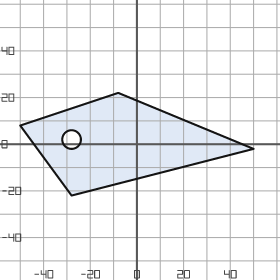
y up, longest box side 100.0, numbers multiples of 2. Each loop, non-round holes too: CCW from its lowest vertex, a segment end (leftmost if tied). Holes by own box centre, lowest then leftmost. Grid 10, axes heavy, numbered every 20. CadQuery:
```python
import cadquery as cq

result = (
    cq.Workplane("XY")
    .moveTo(-28.0, -22.0)
    .lineTo(50.0, -2.0)
    .lineTo(-8.0, 22.0)
    .lineTo(-50.0, 8.0)
    .close()
    .moveTo(-28.0, 2.0)
    .circle(4.0)
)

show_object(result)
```